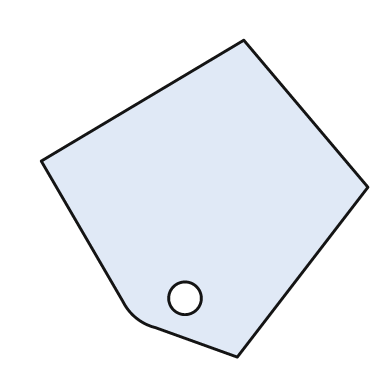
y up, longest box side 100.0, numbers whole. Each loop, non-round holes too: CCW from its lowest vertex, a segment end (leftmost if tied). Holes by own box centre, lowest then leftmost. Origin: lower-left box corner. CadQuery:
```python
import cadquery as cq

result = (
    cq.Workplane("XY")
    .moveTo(60.0, 0.0)
    .lineTo(100.0, 52.0)
    .lineTo(62.0, 97.0)
    .lineTo(0.0, 60.0)
    .lineTo(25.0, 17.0)
    .threePointArc((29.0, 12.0), (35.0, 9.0))
    .close()
    .moveTo(44.0, 18.0)
    .circle(5.0)
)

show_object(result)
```